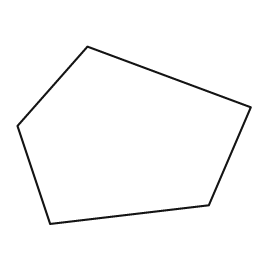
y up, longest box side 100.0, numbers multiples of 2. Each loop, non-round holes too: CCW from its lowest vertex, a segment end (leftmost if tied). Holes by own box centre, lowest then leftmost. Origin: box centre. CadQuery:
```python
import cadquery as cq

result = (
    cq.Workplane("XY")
    .moveTo(-36.0, -38.0)
    .lineTo(32.0, -30.0)
    .lineTo(50.0, 12.0)
    .lineTo(-20.0, 38.0)
    .lineTo(-50.0, 4.0)
    .close()
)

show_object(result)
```